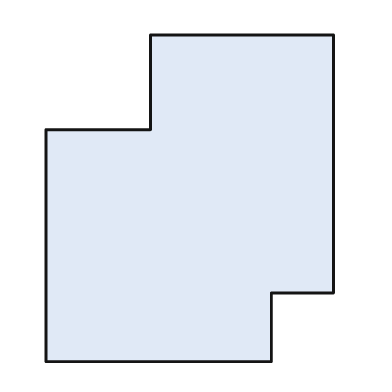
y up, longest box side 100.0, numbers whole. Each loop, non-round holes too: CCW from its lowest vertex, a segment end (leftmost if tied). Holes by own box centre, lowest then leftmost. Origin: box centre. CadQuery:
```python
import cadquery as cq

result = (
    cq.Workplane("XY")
    .moveTo(-44.0, -50.0)
    .lineTo(25.0, -50.0)
    .lineTo(25.0, -29.0)
    .lineTo(44.0, -29.0)
    .lineTo(44.0, 50.0)
    .lineTo(-12.0, 50.0)
    .lineTo(-12.0, 21.0)
    .lineTo(-44.0, 21.0)
    .close()
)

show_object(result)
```